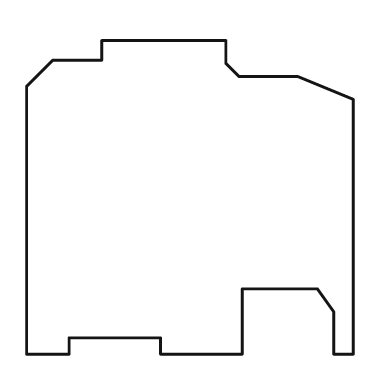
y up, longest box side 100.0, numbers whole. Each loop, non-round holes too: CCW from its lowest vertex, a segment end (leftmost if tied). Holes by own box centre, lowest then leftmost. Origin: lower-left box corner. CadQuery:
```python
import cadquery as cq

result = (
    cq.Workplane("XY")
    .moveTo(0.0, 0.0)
    .lineTo(13.0, 0.0)
    .lineTo(13.0, 5.0)
    .lineTo(41.0, 5.0)
    .lineTo(41.0, 0.0)
    .lineTo(66.0, 0.0)
    .lineTo(66.0, 20.0)
    .lineTo(89.0, 20.0)
    .lineTo(94.0, 13.0)
    .lineTo(94.0, 0.0)
    .lineTo(100.0, 0.0)
    .lineTo(100.0, 78.0)
    .lineTo(83.0, 85.0)
    .lineTo(65.0, 85.0)
    .lineTo(61.0, 89.0)
    .lineTo(61.0, 96.0)
    .lineTo(23.0, 96.0)
    .lineTo(23.0, 90.0)
    .lineTo(8.0, 90.0)
    .lineTo(0.0, 82.0)
    .close()
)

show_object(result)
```